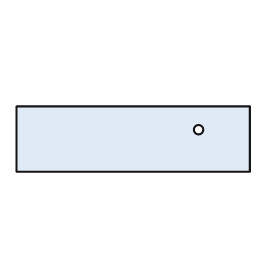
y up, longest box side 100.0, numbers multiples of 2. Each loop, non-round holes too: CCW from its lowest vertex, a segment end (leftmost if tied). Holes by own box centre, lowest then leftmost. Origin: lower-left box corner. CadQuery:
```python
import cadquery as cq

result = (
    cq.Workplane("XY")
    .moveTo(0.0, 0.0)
    .lineTo(100.0, 0.0)
    .lineTo(100.0, 28.0)
    .lineTo(0.0, 28.0)
    .close()
    .moveTo(78.0, 18.0)
    .circle(2.0)
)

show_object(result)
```